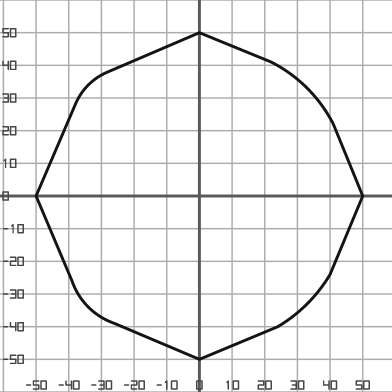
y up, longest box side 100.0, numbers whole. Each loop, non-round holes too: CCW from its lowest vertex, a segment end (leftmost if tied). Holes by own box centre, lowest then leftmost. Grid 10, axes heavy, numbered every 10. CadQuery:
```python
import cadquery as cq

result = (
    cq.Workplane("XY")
    .moveTo(0.0, -50.0)
    .lineTo(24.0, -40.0)
    .threePointArc((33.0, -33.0), (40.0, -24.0))
    .lineTo(50.0, 0.0)
    .lineTo(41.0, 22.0)
    .threePointArc((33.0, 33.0), (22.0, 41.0))
    .lineTo(0.0, 50.0)
    .lineTo(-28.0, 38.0)
    .threePointArc((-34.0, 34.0), (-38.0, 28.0))
    .lineTo(-50.0, 0.0)
    .lineTo(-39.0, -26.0)
    .threePointArc((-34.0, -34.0), (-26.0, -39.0))
    .close()
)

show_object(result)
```